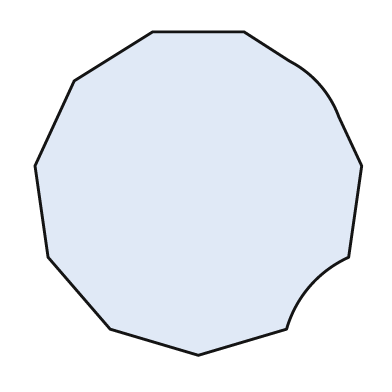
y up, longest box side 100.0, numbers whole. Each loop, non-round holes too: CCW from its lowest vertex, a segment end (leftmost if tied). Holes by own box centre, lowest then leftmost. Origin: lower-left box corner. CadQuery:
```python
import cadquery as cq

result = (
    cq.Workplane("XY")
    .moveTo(50.0, 0.0)
    .lineTo(77.0, 8.0)
    .threePointArc((84.0, 21.0), (96.0, 30.0))
    .lineTo(100.0, 58.0)
    .lineTo(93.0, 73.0)
    .threePointArc((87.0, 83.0), (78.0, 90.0))
    .lineTo(64.0, 99.0)
    .lineTo(36.0, 99.0)
    .lineTo(12.0, 84.0)
    .lineTo(0.0, 58.0)
    .lineTo(4.0, 30.0)
    .lineTo(23.0, 8.0)
    .close()
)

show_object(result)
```